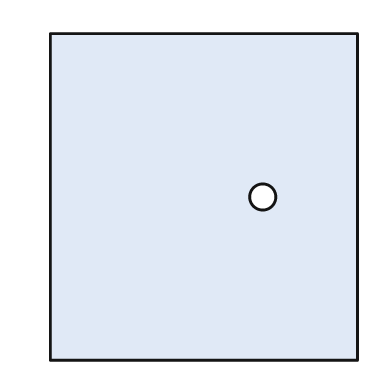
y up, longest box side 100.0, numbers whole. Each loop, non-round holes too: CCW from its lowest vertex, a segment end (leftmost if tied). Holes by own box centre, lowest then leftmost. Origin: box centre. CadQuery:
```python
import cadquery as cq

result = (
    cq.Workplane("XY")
    .moveTo(-47.0, -50.0)
    .lineTo(47.0, -50.0)
    .lineTo(47.0, 50.0)
    .lineTo(-47.0, 50.0)
    .close()
    .moveTo(18.0, 0.0)
    .circle(4.0)
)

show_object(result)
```